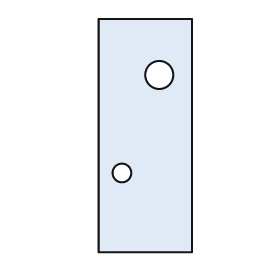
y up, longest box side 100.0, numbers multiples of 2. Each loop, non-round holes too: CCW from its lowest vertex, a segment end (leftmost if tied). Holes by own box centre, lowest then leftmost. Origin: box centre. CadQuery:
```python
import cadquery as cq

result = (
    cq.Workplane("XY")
    .moveTo(-20.0, -50.0)
    .lineTo(20.0, -50.0)
    .lineTo(20.0, 50.0)
    .lineTo(-20.0, 50.0)
    .close()
    .moveTo(-10.0, -16.0)
    .circle(4.0)
    .moveTo(6.0, 26.0)
    .circle(6.0)
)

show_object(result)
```